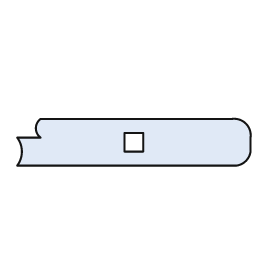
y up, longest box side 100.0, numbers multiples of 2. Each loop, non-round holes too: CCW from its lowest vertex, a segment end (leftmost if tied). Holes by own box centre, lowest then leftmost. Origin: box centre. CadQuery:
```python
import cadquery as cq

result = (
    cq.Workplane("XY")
    .moveTo(-50.0, -10.0)
    .lineTo(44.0, -10.0)
    .threePointArc((48.0, -8.0), (50.0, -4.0))
    .lineTo(50.0, 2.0)
    .threePointArc((48.0, 8.0), (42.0, 10.0))
    .lineTo(-40.0, 10.0)
    .threePointArc((-42.0, 6.0), (-40.0, 2.0))
    .lineTo(-50.0, 2.0)
    .threePointArc((-48.0, -4.0), (-50.0, -10.0))
    .close()
    .moveTo(-4.0, -4.0)
    .lineTo(4.0, -4.0)
    .lineTo(4.0, 4.0)
    .lineTo(-4.0, 4.0)
    .close()
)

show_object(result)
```